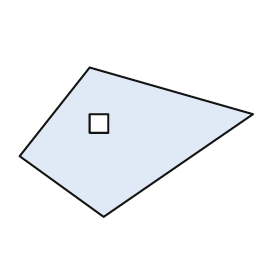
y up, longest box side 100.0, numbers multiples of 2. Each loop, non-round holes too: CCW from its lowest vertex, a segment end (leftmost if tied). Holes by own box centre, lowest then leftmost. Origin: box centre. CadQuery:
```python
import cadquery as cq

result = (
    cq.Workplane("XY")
    .moveTo(-14.0, -32.0)
    .lineTo(50.0, 12.0)
    .lineTo(-20.0, 32.0)
    .lineTo(-50.0, -6.0)
    .close()
    .moveTo(-20.0, 4.0)
    .lineTo(-12.0, 4.0)
    .lineTo(-12.0, 12.0)
    .lineTo(-20.0, 12.0)
    .close()
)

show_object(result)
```